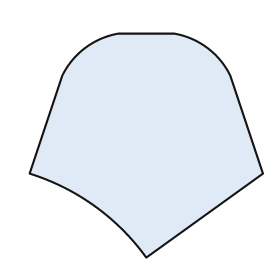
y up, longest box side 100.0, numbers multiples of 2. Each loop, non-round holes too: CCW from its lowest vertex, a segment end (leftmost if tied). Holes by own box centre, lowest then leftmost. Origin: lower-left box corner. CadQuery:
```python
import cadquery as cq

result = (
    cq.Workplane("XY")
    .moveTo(50.0, 0.0)
    .lineTo(100.0, 36.0)
    .lineTo(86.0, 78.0)
    .threePointArc((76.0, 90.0), (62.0, 96.0))
    .lineTo(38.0, 96.0)
    .threePointArc((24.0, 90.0), (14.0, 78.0))
    .lineTo(0.0, 36.0)
    .threePointArc((28.0, 22.0), (50.0, 0.0))
    .close()
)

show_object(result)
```